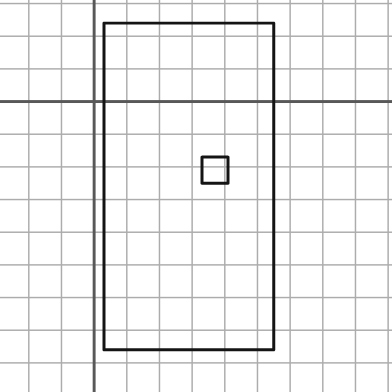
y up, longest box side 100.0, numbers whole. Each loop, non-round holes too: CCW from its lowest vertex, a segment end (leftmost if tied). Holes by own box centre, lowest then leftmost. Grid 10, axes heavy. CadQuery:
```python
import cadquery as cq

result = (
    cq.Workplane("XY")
    .moveTo(3.0, -76.0)
    .lineTo(55.0, -76.0)
    .lineTo(55.0, 24.0)
    .lineTo(3.0, 24.0)
    .close()
    .moveTo(33.0, -25.0)
    .lineTo(41.0, -25.0)
    .lineTo(41.0, -17.0)
    .lineTo(33.0, -17.0)
    .close()
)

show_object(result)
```